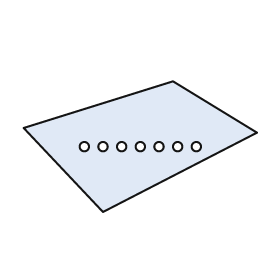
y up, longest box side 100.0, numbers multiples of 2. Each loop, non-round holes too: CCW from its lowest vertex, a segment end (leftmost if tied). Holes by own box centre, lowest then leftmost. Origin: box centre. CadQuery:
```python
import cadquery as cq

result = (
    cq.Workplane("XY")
    .moveTo(-16.0, -28.0)
    .lineTo(50.0, 6.0)
    .lineTo(14.0, 28.0)
    .lineTo(-50.0, 8.0)
    .close()
    .moveTo(-24.0, 0.0)
    .circle(2.0)
    .moveTo(-16.0, 0.0)
    .circle(2.0)
    .moveTo(-8.0, 0.0)
    .circle(2.0)
    .moveTo(0.0, 0.0)
    .circle(2.0)
    .moveTo(8.0, 0.0)
    .circle(2.0)
    .moveTo(16.0, 0.0)
    .circle(2.0)
    .moveTo(24.0, 0.0)
    .circle(2.0)
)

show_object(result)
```